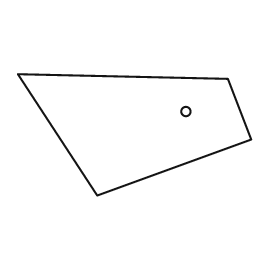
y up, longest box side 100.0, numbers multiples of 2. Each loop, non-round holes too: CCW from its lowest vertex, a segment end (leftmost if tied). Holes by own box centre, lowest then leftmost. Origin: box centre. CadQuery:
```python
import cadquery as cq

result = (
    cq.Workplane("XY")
    .moveTo(-16.0, -26.0)
    .lineTo(50.0, -2.0)
    .lineTo(40.0, 24.0)
    .lineTo(-50.0, 26.0)
    .close()
    .moveTo(22.0, 10.0)
    .circle(2.0)
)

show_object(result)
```